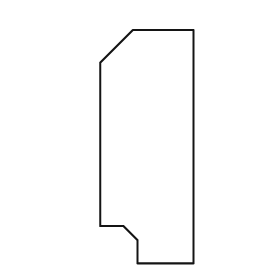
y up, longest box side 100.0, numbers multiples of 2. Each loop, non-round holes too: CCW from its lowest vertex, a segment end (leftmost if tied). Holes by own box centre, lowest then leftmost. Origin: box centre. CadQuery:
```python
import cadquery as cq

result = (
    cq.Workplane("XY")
    .moveTo(-4.0, -50.0)
    .lineTo(20.0, -50.0)
    .lineTo(20.0, 50.0)
    .lineTo(-6.0, 50.0)
    .lineTo(-20.0, 36.0)
    .lineTo(-20.0, -34.0)
    .lineTo(-10.0, -34.0)
    .lineTo(-4.0, -40.0)
    .close()
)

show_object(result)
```